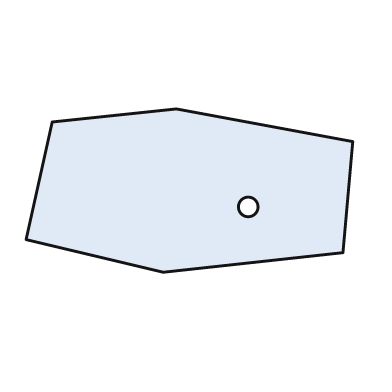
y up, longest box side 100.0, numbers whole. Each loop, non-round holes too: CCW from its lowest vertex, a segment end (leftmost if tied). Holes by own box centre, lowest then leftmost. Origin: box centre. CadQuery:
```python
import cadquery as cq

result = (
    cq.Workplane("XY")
    .moveTo(-8.0, -25.0)
    .lineTo(47.0, -19.0)
    .lineTo(50.0, 15.0)
    .lineTo(-4.0, 25.0)
    .lineTo(-42.0, 21.0)
    .lineTo(-50.0, -15.0)
    .close()
    .moveTo(18.0, -5.0)
    .circle(3.0)
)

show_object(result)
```